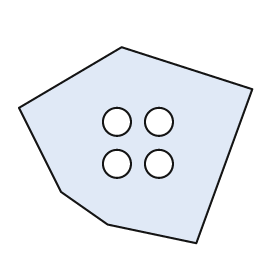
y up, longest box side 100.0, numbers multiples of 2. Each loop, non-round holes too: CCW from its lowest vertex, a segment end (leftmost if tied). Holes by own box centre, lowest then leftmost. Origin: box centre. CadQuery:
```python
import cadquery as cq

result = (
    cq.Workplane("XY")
    .moveTo(26.0, -42.0)
    .lineTo(50.0, 24.0)
    .lineTo(-6.0, 42.0)
    .lineTo(-50.0, 16.0)
    .lineTo(-32.0, -20.0)
    .lineTo(-12.0, -34.0)
    .close()
    .moveTo(-8.0, -8.0)
    .circle(6.0)
    .moveTo(10.0, -8.0)
    .circle(6.0)
    .moveTo(-8.0, 10.0)
    .circle(6.0)
    .moveTo(10.0, 10.0)
    .circle(6.0)
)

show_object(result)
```